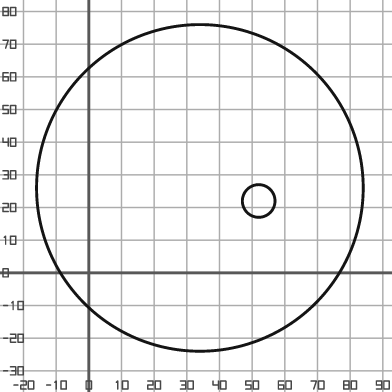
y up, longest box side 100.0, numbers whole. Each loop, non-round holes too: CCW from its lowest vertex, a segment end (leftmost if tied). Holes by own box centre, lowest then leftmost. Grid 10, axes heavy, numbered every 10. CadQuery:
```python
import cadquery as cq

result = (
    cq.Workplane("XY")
    .moveTo(34.0, 26.0)
    .circle(50.0)
    .moveTo(52.0, 22.0)
    .circle(5.0)
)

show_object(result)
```